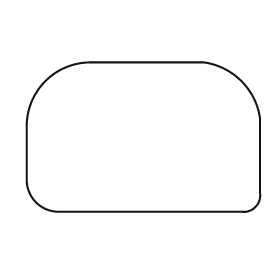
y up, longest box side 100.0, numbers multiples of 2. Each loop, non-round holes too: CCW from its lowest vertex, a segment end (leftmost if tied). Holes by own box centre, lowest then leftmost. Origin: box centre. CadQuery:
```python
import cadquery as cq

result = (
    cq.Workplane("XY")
    .moveTo(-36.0, -32.0)
    .lineTo(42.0, -32.0)
    .threePointArc((48.0, -30.0), (50.0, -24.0))
    .lineTo(50.0, 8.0)
    .threePointArc((42.0, 24.0), (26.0, 32.0))
    .lineTo(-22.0, 32.0)
    .threePointArc((-42.0, 24.0), (-50.0, 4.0))
    .lineTo(-50.0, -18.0)
    .threePointArc((-46.0, -28.0), (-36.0, -32.0))
    .close()
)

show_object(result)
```